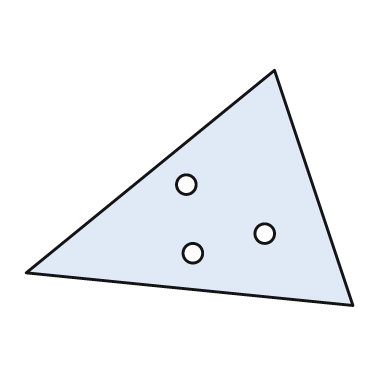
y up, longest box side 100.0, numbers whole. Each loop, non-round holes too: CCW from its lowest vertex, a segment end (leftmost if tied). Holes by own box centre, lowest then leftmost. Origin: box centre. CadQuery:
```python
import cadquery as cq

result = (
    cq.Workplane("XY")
    .moveTo(50.0, -36.0)
    .lineTo(26.0, 36.0)
    .lineTo(-50.0, -26.0)
    .close()
    .moveTo(1.0, -20.0)
    .circle(3.0)
    .moveTo(23.0, -14.0)
    .circle(3.0)
    .moveTo(-1.0, 1.0)
    .circle(3.0)
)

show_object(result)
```